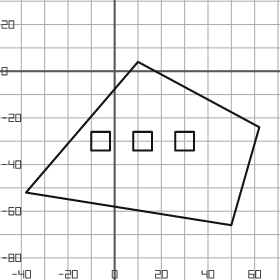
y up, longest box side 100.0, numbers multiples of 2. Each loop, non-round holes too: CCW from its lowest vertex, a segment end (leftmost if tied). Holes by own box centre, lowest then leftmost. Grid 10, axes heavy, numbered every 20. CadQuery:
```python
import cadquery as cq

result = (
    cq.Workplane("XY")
    .moveTo(50.0, -66.0)
    .lineTo(62.0, -24.0)
    .lineTo(10.0, 4.0)
    .lineTo(-38.0, -52.0)
    .close()
    .moveTo(-10.0, -34.0)
    .lineTo(-2.0, -34.0)
    .lineTo(-2.0, -26.0)
    .lineTo(-10.0, -26.0)
    .close()
    .moveTo(8.0, -34.0)
    .lineTo(16.0, -34.0)
    .lineTo(16.0, -26.0)
    .lineTo(8.0, -26.0)
    .close()
    .moveTo(26.0, -34.0)
    .lineTo(34.0, -34.0)
    .lineTo(34.0, -26.0)
    .lineTo(26.0, -26.0)
    .close()
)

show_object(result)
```